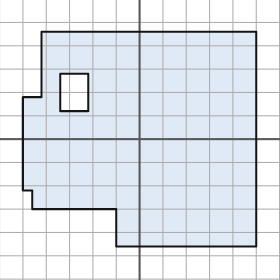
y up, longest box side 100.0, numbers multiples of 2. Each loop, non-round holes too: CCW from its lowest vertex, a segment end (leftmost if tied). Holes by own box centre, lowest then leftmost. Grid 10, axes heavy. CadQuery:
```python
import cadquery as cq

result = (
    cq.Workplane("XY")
    .moveTo(-10.0, -46.0)
    .lineTo(50.0, -46.0)
    .lineTo(50.0, 46.0)
    .lineTo(-42.0, 46.0)
    .lineTo(-42.0, 18.0)
    .lineTo(-50.0, 18.0)
    .lineTo(-50.0, -22.0)
    .lineTo(-46.0, -22.0)
    .lineTo(-46.0, -30.0)
    .lineTo(-10.0, -30.0)
    .close()
    .moveTo(-34.0, 12.0)
    .lineTo(-22.0, 12.0)
    .lineTo(-22.0, 28.0)
    .lineTo(-34.0, 28.0)
    .close()
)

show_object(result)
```